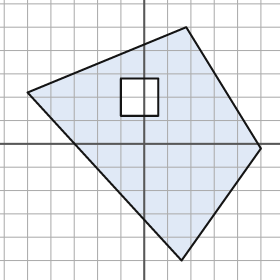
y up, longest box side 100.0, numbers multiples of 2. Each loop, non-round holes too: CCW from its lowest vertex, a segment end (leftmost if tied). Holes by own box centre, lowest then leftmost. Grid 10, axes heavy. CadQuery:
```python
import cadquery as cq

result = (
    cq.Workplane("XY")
    .moveTo(16.0, -50.0)
    .lineTo(50.0, -2.0)
    .lineTo(18.0, 50.0)
    .lineTo(-50.0, 22.0)
    .close()
    .moveTo(-10.0, 12.0)
    .lineTo(6.0, 12.0)
    .lineTo(6.0, 28.0)
    .lineTo(-10.0, 28.0)
    .close()
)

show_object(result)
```